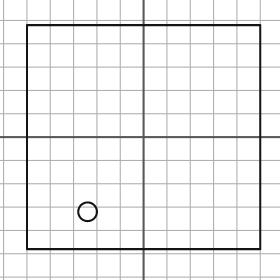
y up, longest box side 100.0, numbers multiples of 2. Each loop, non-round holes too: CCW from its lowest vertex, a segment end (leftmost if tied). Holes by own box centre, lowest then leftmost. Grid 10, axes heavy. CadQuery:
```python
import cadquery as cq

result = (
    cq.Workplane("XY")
    .moveTo(-50.0, -48.0)
    .lineTo(50.0, -48.0)
    .lineTo(50.0, 48.0)
    .lineTo(-50.0, 48.0)
    .close()
    .moveTo(-24.0, -32.0)
    .circle(4.0)
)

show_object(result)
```